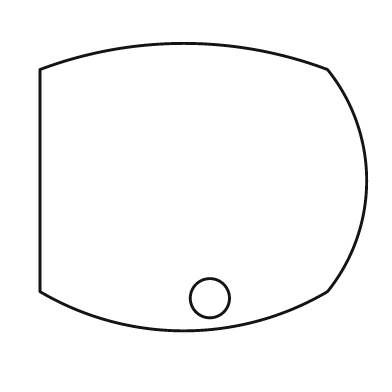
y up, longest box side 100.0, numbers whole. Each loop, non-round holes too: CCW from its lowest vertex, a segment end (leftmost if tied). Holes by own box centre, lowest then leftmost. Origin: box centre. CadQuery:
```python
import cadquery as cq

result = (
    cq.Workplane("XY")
    .moveTo(-50.0, -32.0)
    .threePointArc((-6.0, -44.0), (38.0, -32.0))
    .threePointArc((50.0, 2.0), (38.0, 36.0))
    .threePointArc((-6.0, 44.0), (-50.0, 36.0))
    .close()
    .moveTo(2.0, -34.0)
    .circle(6.0)
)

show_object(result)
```